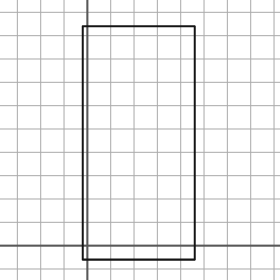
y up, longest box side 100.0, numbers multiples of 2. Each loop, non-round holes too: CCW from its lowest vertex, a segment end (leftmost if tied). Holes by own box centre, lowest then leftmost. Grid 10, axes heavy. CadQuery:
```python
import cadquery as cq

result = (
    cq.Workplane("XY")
    .moveTo(-2.0, -6.0)
    .lineTo(46.0, -6.0)
    .lineTo(46.0, 94.0)
    .lineTo(-2.0, 94.0)
    .close()
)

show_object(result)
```